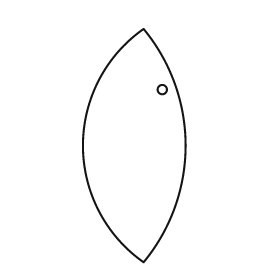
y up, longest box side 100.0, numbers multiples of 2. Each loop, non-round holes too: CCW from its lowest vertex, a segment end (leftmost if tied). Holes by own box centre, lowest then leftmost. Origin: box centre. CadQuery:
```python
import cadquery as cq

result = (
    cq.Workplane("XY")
    .moveTo(4.0, -50.0)
    .threePointArc((22.0, 0.0), (4.0, 50.0))
    .threePointArc((-22.0, 0.0), (4.0, -50.0))
    .close()
    .moveTo(12.0, 24.0)
    .circle(2.0)
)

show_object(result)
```